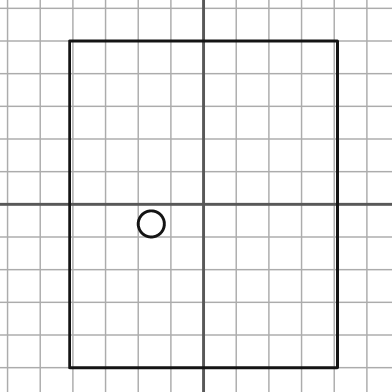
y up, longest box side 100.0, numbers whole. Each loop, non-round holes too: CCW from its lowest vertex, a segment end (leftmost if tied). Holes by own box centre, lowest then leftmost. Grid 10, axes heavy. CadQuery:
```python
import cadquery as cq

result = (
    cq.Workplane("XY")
    .moveTo(-41.0, -50.0)
    .lineTo(41.0, -50.0)
    .lineTo(41.0, 50.0)
    .lineTo(-41.0, 50.0)
    .close()
    .moveTo(-16.0, -6.0)
    .circle(4.0)
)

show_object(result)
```